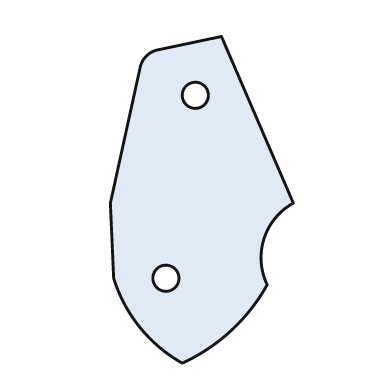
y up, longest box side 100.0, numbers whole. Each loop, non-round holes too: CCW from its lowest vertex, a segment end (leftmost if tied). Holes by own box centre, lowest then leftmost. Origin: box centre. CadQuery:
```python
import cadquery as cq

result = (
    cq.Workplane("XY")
    .moveTo(-6.0, -50.0)
    .threePointArc((9.0, -40.0), (20.0, -26.0))
    .threePointArc((19.0, -12.0), (28.0, -1.0))
    .lineTo(6.0, 50.0)
    .lineTo(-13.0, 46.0)
    .threePointArc((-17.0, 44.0), (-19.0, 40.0))
    .lineTo(-28.0, -1.0)
    .lineTo(-27.0, -24.0)
    .threePointArc((-19.0, -39.0), (-6.0, -50.0))
    .close()
    .moveTo(-11.0, -24.0)
    .circle(4.0)
    .moveTo(-2.0, 32.0)
    .circle(4.0)
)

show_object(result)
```